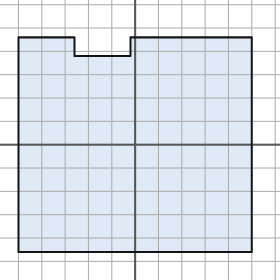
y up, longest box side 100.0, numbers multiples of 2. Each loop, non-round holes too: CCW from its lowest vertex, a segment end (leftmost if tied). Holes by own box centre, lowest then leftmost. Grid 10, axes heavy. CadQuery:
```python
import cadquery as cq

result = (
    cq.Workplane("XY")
    .moveTo(-50.0, -46.0)
    .lineTo(50.0, -46.0)
    .lineTo(50.0, 46.0)
    .lineTo(-2.0, 46.0)
    .lineTo(-2.0, 38.0)
    .lineTo(-26.0, 38.0)
    .lineTo(-26.0, 46.0)
    .lineTo(-50.0, 46.0)
    .close()
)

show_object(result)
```